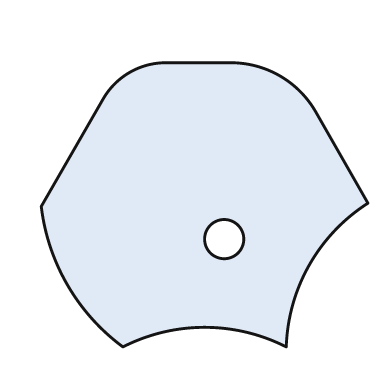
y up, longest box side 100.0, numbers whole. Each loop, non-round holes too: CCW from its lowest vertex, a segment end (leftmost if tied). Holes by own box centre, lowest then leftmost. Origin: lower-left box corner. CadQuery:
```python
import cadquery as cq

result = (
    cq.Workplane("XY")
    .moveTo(25.0, 0.0)
    .threePointArc((50.0, 6.0), (75.0, 0.0))
    .threePointArc((82.0, 25.0), (100.0, 44.0))
    .lineTo(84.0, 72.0)
    .threePointArc((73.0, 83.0), (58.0, 87.0))
    .lineTo(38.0, 87.0)
    .threePointArc((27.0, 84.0), (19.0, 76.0))
    .lineTo(0.0, 43.0)
    .threePointArc((8.0, 19.0), (25.0, 0.0))
    .close()
    .moveTo(56.0, 33.0)
    .circle(6.0)
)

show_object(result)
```